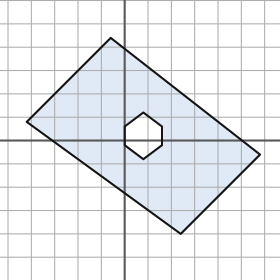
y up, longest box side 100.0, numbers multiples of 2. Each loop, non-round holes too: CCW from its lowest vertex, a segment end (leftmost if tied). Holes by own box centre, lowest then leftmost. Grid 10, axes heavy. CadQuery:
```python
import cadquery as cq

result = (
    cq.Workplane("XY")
    .moveTo(24.0, -40.0)
    .lineTo(58.0, -6.0)
    .lineTo(-6.0, 44.0)
    .lineTo(-42.0, 8.0)
    .close()
    .moveTo(8.0, -8.0)
    .lineTo(16.0, -2.0)
    .lineTo(16.0, 6.0)
    .lineTo(8.0, 12.0)
    .lineTo(0.0, 6.0)
    .lineTo(0.0, -2.0)
    .close()
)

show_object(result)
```